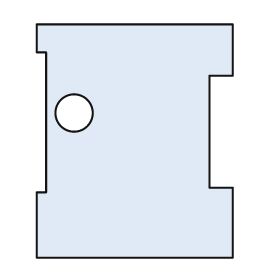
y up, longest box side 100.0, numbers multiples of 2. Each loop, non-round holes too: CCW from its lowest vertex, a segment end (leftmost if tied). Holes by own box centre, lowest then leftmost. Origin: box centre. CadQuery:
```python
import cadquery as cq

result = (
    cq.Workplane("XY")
    .moveTo(-42.0, -50.0)
    .lineTo(42.0, -50.0)
    .lineTo(42.0, -20.0)
    .lineTo(32.0, -20.0)
    .lineTo(32.0, 28.0)
    .lineTo(42.0, 28.0)
    .lineTo(42.0, 50.0)
    .lineTo(-42.0, 50.0)
    .lineTo(-42.0, 38.0)
    .lineTo(-38.0, 38.0)
    .lineTo(-38.0, -22.0)
    .lineTo(-42.0, -22.0)
    .close()
    .moveTo(-26.0, 12.0)
    .circle(8.0)
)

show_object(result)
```